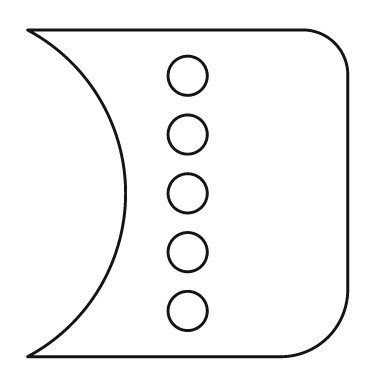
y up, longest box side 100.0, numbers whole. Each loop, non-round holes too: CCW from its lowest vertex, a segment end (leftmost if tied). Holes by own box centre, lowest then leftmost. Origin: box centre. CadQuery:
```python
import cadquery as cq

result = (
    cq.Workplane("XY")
    .moveTo(-49.0, -50.0)
    .lineTo(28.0, -50.0)
    .threePointArc((43.0, -44.0), (49.0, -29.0))
    .lineTo(49.0, 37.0)
    .threePointArc((45.0, 46.0), (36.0, 50.0))
    .lineTo(-49.0, 50.0)
    .threePointArc((-19.0, 0.0), (-49.0, -50.0))
    .close()
    .moveTo(0.0, -36.0)
    .circle(6.0)
    .moveTo(0.0, -18.0)
    .circle(6.0)
    .moveTo(0.0, 0.0)
    .circle(6.0)
    .moveTo(0.0, 18.0)
    .circle(6.0)
    .moveTo(0.0, 36.0)
    .circle(6.0)
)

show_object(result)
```